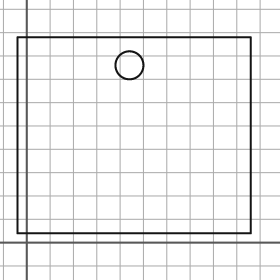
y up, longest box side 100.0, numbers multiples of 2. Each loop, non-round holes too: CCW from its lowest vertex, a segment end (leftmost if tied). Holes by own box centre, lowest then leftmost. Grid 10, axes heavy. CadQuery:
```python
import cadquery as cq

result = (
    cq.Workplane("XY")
    .moveTo(-4.0, 4.0)
    .lineTo(96.0, 4.0)
    .lineTo(96.0, 88.0)
    .lineTo(-4.0, 88.0)
    .close()
    .moveTo(44.0, 76.0)
    .circle(6.0)
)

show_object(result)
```